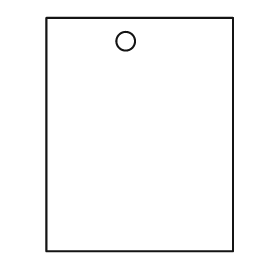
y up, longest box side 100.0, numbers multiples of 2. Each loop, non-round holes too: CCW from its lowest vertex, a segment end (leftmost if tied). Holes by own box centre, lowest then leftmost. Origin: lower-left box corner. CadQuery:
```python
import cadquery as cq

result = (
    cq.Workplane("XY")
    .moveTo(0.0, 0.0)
    .lineTo(80.0, 0.0)
    .lineTo(80.0, 100.0)
    .lineTo(0.0, 100.0)
    .close()
    .moveTo(34.0, 90.0)
    .circle(4.0)
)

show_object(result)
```